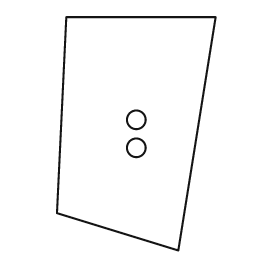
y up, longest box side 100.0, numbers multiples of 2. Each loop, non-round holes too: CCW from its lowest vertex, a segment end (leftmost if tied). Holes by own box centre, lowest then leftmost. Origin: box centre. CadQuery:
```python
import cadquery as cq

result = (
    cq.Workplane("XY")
    .moveTo(18.0, -50.0)
    .lineTo(34.0, 50.0)
    .lineTo(-30.0, 50.0)
    .lineTo(-34.0, -34.0)
    .close()
    .moveTo(0.0, -6.0)
    .circle(4.0)
    .moveTo(0.0, 6.0)
    .circle(4.0)
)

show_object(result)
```